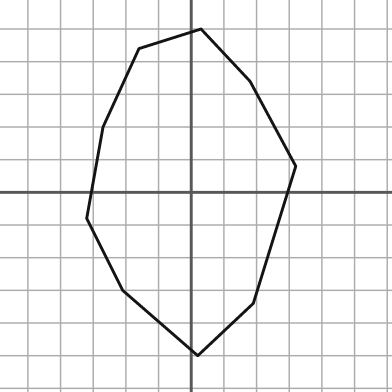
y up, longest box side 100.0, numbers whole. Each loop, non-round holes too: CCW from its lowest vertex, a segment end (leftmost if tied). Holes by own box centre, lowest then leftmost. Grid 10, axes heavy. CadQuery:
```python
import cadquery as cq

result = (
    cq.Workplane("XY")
    .moveTo(2.0, -50.0)
    .lineTo(19.0, -34.0)
    .lineTo(32.0, 8.0)
    .lineTo(18.0, 34.0)
    .lineTo(3.0, 50.0)
    .lineTo(-16.0, 44.0)
    .lineTo(-27.0, 20.0)
    .lineTo(-32.0, -8.0)
    .lineTo(-21.0, -30.0)
    .close()
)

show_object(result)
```